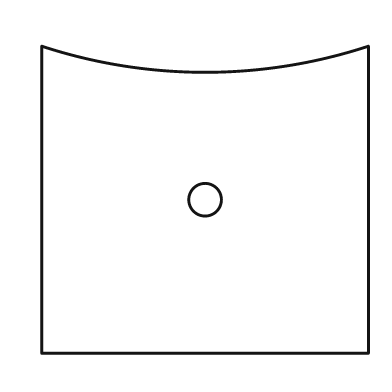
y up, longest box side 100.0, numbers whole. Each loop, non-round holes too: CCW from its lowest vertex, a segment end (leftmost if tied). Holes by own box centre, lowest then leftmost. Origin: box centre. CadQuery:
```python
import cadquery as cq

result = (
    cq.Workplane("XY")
    .moveTo(-50.0, -47.0)
    .lineTo(50.0, -47.0)
    .lineTo(50.0, 47.0)
    .threePointArc((0.0, 39.0), (-50.0, 47.0))
    .close()
    .moveTo(0.0, 0.0)
    .circle(5.0)
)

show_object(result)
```